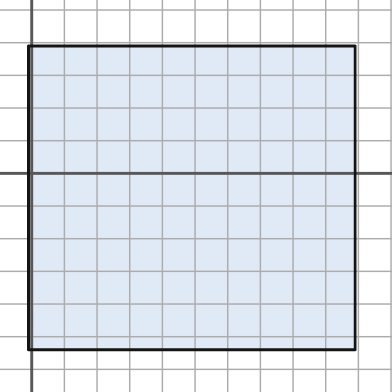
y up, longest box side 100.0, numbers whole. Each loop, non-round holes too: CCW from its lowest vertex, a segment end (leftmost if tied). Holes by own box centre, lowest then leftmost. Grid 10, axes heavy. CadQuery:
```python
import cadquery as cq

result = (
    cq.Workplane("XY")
    .moveTo(-1.0, -54.0)
    .lineTo(99.0, -54.0)
    .lineTo(99.0, 39.0)
    .lineTo(-1.0, 39.0)
    .close()
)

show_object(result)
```